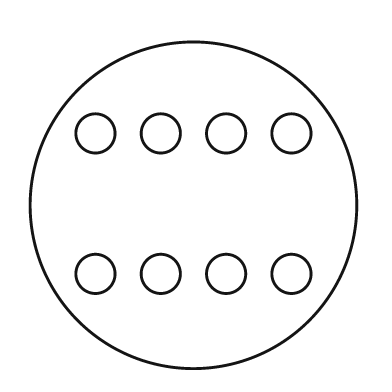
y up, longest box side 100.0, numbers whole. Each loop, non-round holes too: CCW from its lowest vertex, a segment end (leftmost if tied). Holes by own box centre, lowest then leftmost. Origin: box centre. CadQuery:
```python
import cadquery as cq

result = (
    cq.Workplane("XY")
    .moveTo(0.0, 0.0)
    .circle(50.0)
    .moveTo(-30.0, -21.0)
    .circle(6.0)
    .moveTo(-10.0, -21.0)
    .circle(6.0)
    .moveTo(10.0, -21.0)
    .circle(6.0)
    .moveTo(30.0, -21.0)
    .circle(6.0)
    .moveTo(-30.0, 22.0)
    .circle(6.0)
    .moveTo(-10.0, 22.0)
    .circle(6.0)
    .moveTo(10.0, 22.0)
    .circle(6.0)
    .moveTo(30.0, 22.0)
    .circle(6.0)
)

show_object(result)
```